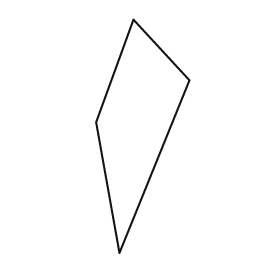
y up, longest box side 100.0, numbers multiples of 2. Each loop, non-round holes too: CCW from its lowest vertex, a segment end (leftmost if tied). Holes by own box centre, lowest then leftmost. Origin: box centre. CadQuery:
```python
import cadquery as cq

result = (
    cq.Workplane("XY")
    .moveTo(-10.0, -50.0)
    .lineTo(20.0, 24.0)
    .lineTo(-4.0, 50.0)
    .lineTo(-20.0, 6.0)
    .close()
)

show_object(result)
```